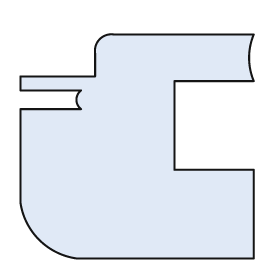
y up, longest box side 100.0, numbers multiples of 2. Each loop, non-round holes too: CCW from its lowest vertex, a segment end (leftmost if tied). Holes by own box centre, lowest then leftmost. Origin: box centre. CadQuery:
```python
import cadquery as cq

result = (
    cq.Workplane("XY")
    .moveTo(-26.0, -48.0)
    .lineTo(50.0, -48.0)
    .lineTo(50.0, -10.0)
    .lineTo(16.0, -10.0)
    .lineTo(16.0, 28.0)
    .lineTo(50.0, 28.0)
    .threePointArc((48.0, 38.0), (50.0, 48.0))
    .lineTo(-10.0, 48.0)
    .threePointArc((-16.0, 46.0), (-18.0, 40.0))
    .lineTo(-18.0, 30.0)
    .lineTo(-50.0, 30.0)
    .lineTo(-50.0, 24.0)
    .lineTo(-24.0, 24.0)
    .threePointArc((-26.0, 20.0), (-24.0, 16.0))
    .lineTo(-50.0, 16.0)
    .lineTo(-50.0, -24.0)
    .threePointArc((-42.0, -40.0), (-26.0, -48.0))
    .close()
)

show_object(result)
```